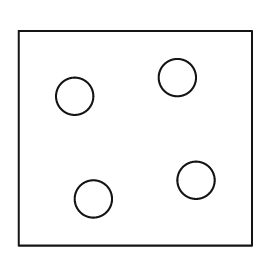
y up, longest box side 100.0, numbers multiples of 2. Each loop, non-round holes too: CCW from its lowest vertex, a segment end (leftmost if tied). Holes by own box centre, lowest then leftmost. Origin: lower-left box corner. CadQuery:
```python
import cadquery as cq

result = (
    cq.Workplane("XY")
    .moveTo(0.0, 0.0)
    .lineTo(100.0, 0.0)
    .lineTo(100.0, 92.0)
    .lineTo(0.0, 92.0)
    .close()
    .moveTo(32.0, 20.0)
    .circle(8.0)
    .moveTo(76.0, 28.0)
    .circle(8.0)
    .moveTo(24.0, 64.0)
    .circle(8.0)
    .moveTo(68.0, 72.0)
    .circle(8.0)
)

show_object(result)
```